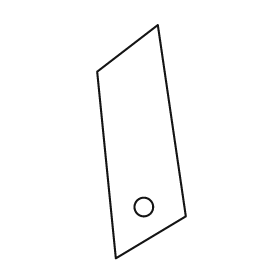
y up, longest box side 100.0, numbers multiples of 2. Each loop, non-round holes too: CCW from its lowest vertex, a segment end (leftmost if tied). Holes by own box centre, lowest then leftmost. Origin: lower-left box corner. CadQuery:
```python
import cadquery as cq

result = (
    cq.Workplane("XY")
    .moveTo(8.0, 0.0)
    .lineTo(38.0, 18.0)
    .lineTo(26.0, 100.0)
    .lineTo(0.0, 80.0)
    .close()
    .moveTo(20.0, 22.0)
    .circle(4.0)
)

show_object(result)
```